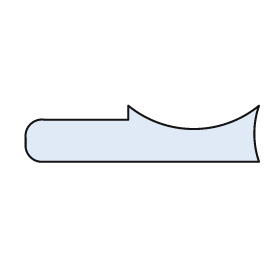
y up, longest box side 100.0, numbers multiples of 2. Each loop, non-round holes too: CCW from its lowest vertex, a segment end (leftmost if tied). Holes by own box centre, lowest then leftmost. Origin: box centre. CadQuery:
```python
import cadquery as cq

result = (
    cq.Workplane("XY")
    .moveTo(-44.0, -12.0)
    .lineTo(50.0, -12.0)
    .threePointArc((48.0, 0.0), (50.0, 12.0))
    .threePointArc((22.0, 2.0), (-6.0, 12.0))
    .lineTo(-6.0, 6.0)
    .lineTo(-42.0, 6.0)
    .threePointArc((-48.0, 4.0), (-50.0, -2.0))
    .lineTo(-50.0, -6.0)
    .threePointArc((-48.0, -10.0), (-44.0, -12.0))
    .close()
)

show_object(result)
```